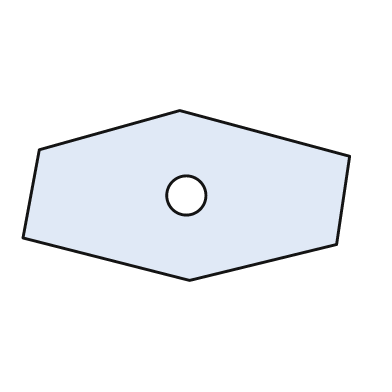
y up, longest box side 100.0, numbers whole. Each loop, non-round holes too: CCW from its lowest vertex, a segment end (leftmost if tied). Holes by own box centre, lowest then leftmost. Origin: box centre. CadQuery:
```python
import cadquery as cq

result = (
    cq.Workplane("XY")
    .moveTo(1.0, -26.0)
    .lineTo(46.0, -15.0)
    .lineTo(50.0, 12.0)
    .lineTo(-2.0, 26.0)
    .lineTo(-45.0, 14.0)
    .lineTo(-50.0, -13.0)
    .close()
    .moveTo(0.0, 0.0)
    .circle(6.0)
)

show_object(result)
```